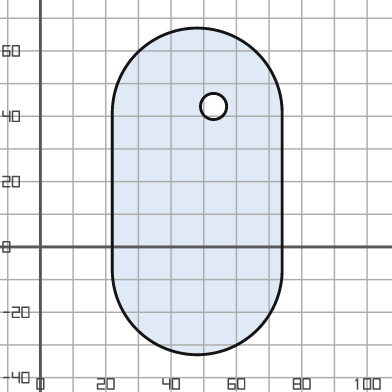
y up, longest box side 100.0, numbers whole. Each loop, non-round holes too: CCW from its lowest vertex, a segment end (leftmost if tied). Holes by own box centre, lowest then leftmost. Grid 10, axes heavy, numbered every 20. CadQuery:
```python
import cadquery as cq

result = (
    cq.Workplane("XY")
    .moveTo(22.0, -7.0)
    .threePointArc((48.0, -33.0), (74.0, -7.0))
    .lineTo(74.0, 41.0)
    .threePointArc((48.0, 67.0), (22.0, 41.0))
    .close()
    .moveTo(53.0, 43.0)
    .circle(4.0)
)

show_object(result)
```